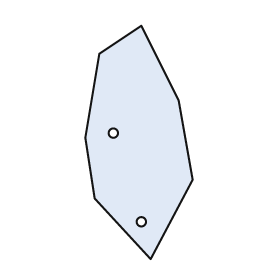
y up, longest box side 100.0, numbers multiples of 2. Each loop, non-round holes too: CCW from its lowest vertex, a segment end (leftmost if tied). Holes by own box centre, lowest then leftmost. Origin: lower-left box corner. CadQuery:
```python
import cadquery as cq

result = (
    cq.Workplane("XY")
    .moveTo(28.0, 0.0)
    .lineTo(46.0, 34.0)
    .lineTo(40.0, 68.0)
    .lineTo(24.0, 100.0)
    .lineTo(6.0, 88.0)
    .lineTo(0.0, 52.0)
    .lineTo(4.0, 26.0)
    .close()
    .moveTo(24.0, 16.0)
    .circle(2.0)
    .moveTo(12.0, 54.0)
    .circle(2.0)
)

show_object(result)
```